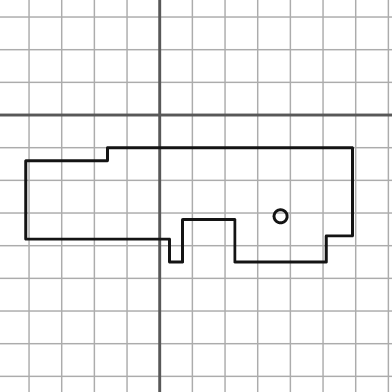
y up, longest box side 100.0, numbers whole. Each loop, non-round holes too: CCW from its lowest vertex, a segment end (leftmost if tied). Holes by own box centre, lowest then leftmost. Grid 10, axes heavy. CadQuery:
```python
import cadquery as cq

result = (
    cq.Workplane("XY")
    .moveTo(3.0, -45.0)
    .lineTo(7.0, -45.0)
    .lineTo(7.0, -32.0)
    .lineTo(23.0, -32.0)
    .lineTo(23.0, -45.0)
    .lineTo(51.0, -45.0)
    .lineTo(51.0, -37.0)
    .lineTo(59.0, -37.0)
    .lineTo(59.0, -10.0)
    .lineTo(-16.0, -10.0)
    .lineTo(-16.0, -14.0)
    .lineTo(-41.0, -14.0)
    .lineTo(-41.0, -38.0)
    .lineTo(3.0, -38.0)
    .close()
    .moveTo(37.0, -31.0)
    .circle(2.0)
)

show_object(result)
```